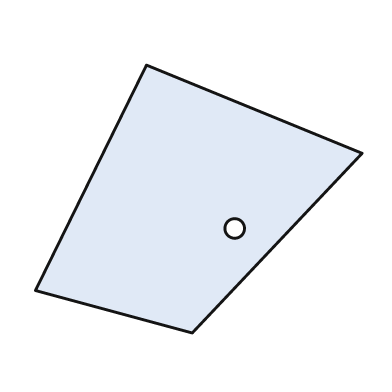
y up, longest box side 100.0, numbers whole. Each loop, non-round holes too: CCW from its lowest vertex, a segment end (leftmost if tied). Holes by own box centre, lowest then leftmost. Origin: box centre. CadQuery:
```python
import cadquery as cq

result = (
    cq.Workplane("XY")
    .moveTo(-2.0, -41.0)
    .lineTo(50.0, 14.0)
    .lineTo(-16.0, 41.0)
    .lineTo(-50.0, -28.0)
    .close()
    .moveTo(11.0, -9.0)
    .circle(3.0)
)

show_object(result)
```